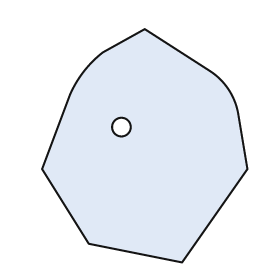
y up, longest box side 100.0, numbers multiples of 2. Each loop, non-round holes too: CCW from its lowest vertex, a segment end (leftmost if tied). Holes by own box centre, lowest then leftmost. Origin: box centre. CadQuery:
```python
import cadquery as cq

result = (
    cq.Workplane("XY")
    .moveTo(16.0, -50.0)
    .lineTo(44.0, -10.0)
    .lineTo(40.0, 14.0)
    .threePointArc((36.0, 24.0), (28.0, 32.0))
    .lineTo(0.0, 50.0)
    .lineTo(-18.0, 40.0)
    .threePointArc((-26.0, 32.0), (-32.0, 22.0))
    .lineTo(-44.0, -10.0)
    .lineTo(-24.0, -42.0)
    .close()
    .moveTo(-10.0, 8.0)
    .circle(4.0)
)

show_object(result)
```